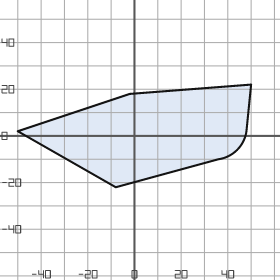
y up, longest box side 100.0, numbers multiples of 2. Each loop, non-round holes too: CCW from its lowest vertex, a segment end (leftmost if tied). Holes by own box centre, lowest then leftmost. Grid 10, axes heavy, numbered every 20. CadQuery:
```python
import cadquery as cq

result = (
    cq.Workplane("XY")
    .moveTo(-8.0, -22.0)
    .lineTo(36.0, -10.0)
    .threePointArc((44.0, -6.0), (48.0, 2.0))
    .lineTo(50.0, 22.0)
    .lineTo(-2.0, 18.0)
    .lineTo(-50.0, 2.0)
    .close()
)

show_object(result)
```